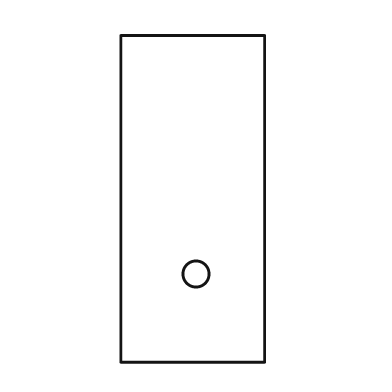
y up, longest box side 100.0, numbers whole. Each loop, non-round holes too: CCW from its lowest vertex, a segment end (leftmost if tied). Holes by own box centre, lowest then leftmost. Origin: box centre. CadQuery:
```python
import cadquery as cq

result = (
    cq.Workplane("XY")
    .moveTo(-22.0, -50.0)
    .lineTo(22.0, -50.0)
    .lineTo(22.0, 50.0)
    .lineTo(-22.0, 50.0)
    .close()
    .moveTo(1.0, -23.0)
    .circle(4.0)
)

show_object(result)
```